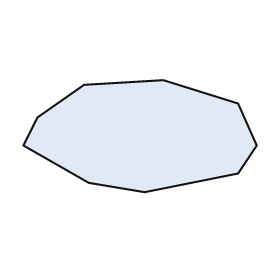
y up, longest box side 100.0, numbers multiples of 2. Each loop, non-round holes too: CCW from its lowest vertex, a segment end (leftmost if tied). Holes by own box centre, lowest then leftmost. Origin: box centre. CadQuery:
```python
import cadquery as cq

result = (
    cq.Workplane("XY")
    .moveTo(2.0, -24.0)
    .lineTo(42.0, -16.0)
    .lineTo(50.0, -4.0)
    .lineTo(42.0, 14.0)
    .lineTo(10.0, 24.0)
    .lineTo(-24.0, 22.0)
    .lineTo(-44.0, 8.0)
    .lineTo(-50.0, -4.0)
    .lineTo(-22.0, -20.0)
    .close()
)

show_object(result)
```